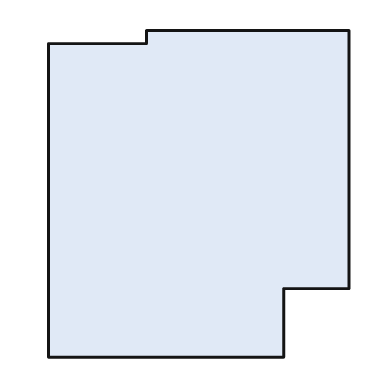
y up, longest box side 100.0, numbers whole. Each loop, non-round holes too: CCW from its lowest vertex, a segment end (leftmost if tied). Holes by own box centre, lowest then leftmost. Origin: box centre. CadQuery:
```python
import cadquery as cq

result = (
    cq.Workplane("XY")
    .moveTo(-46.0, -50.0)
    .lineTo(26.0, -50.0)
    .lineTo(26.0, -29.0)
    .lineTo(46.0, -29.0)
    .lineTo(46.0, 50.0)
    .lineTo(-16.0, 50.0)
    .lineTo(-16.0, 46.0)
    .lineTo(-46.0, 46.0)
    .close()
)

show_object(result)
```